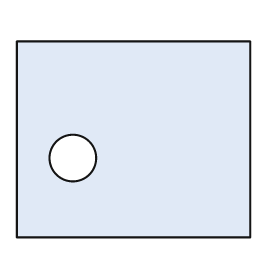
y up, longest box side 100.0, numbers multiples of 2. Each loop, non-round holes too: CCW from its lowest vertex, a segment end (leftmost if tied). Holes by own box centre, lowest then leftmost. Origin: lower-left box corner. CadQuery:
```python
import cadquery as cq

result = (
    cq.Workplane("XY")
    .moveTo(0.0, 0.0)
    .lineTo(100.0, 0.0)
    .lineTo(100.0, 84.0)
    .lineTo(0.0, 84.0)
    .close()
    .moveTo(24.0, 34.0)
    .circle(10.0)
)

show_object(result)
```